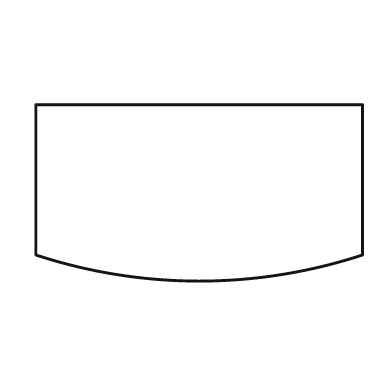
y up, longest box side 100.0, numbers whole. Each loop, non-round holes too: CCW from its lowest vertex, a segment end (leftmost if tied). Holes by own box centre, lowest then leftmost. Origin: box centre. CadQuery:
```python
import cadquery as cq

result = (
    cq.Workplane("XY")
    .moveTo(-50.0, -19.0)
    .threePointArc((0.0, -27.0), (50.0, -19.0))
    .lineTo(50.0, 27.0)
    .lineTo(-50.0, 27.0)
    .close()
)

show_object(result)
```